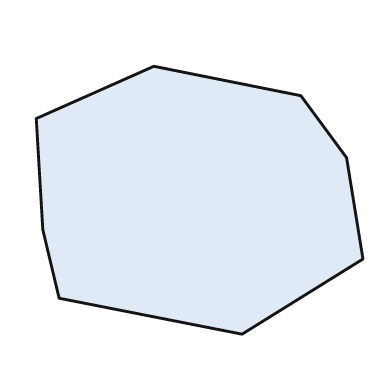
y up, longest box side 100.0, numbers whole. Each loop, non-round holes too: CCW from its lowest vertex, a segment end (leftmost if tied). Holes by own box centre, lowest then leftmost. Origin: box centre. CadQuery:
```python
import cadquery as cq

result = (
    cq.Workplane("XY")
    .moveTo(13.0, -41.0)
    .lineTo(50.0, -18.0)
    .lineTo(45.0, 13.0)
    .lineTo(31.0, 32.0)
    .lineTo(-14.0, 41.0)
    .lineTo(-50.0, 25.0)
    .lineTo(-48.0, -9.0)
    .lineTo(-43.0, -30.0)
    .close()
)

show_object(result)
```